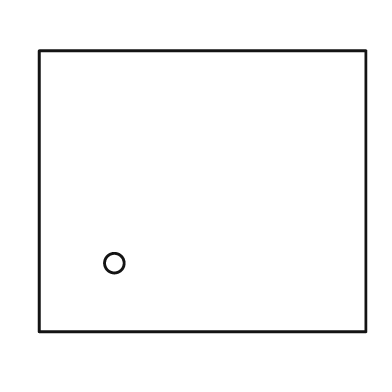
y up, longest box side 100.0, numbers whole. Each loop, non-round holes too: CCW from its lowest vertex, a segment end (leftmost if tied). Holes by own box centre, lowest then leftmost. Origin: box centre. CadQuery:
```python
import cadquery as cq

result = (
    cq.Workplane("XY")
    .moveTo(-50.0, -43.0)
    .lineTo(50.0, -43.0)
    .lineTo(50.0, 43.0)
    .lineTo(-50.0, 43.0)
    .close()
    .moveTo(-27.0, -22.0)
    .circle(3.0)
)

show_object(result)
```